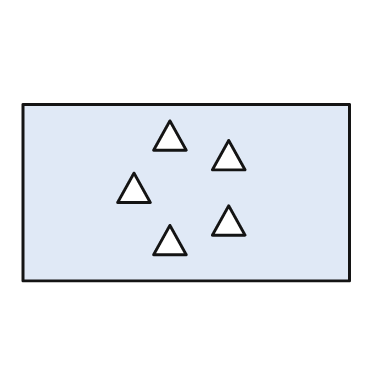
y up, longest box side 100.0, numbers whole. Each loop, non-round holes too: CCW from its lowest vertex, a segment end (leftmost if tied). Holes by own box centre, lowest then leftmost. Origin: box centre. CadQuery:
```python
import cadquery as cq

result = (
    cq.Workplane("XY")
    .moveTo(-50.0, -27.0)
    .lineTo(50.0, -27.0)
    .lineTo(50.0, 27.0)
    .lineTo(-50.0, 27.0)
    .close()
    .moveTo(-10.0, -19.0)
    .lineTo(0.0, -19.0)
    .lineTo(-5.0, -10.0)
    .close()
    .moveTo(8.0, -13.0)
    .lineTo(18.0, -13.0)
    .lineTo(13.0, -4.0)
    .close()
    .moveTo(-21.0, -3.0)
    .lineTo(-11.0, -3.0)
    .lineTo(-16.0, 6.0)
    .close()
    .moveTo(8.0, 7.0)
    .lineTo(18.0, 7.0)
    .lineTo(13.0, 16.0)
    .close()
    .moveTo(-10.0, 13.0)
    .lineTo(0.0, 13.0)
    .lineTo(-5.0, 22.0)
    .close()
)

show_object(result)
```